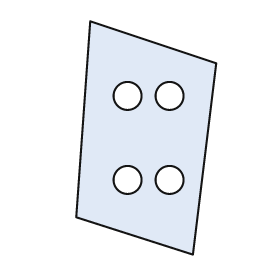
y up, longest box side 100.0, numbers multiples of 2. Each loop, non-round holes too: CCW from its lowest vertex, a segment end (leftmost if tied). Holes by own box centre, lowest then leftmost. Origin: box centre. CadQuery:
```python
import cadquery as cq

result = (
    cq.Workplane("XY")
    .moveTo(20.0, -50.0)
    .lineTo(30.0, 32.0)
    .lineTo(-24.0, 50.0)
    .lineTo(-30.0, -34.0)
    .close()
    .moveTo(-8.0, -18.0)
    .circle(6.0)
    .moveTo(10.0, -18.0)
    .circle(6.0)
    .moveTo(-8.0, 18.0)
    .circle(6.0)
    .moveTo(10.0, 18.0)
    .circle(6.0)
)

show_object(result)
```